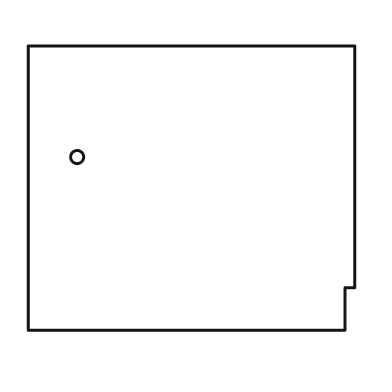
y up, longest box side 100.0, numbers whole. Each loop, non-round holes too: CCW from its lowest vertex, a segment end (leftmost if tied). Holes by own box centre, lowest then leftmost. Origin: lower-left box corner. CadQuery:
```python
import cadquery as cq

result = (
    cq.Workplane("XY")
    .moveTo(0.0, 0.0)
    .lineTo(97.0, 0.0)
    .lineTo(97.0, 13.0)
    .lineTo(100.0, 13.0)
    .lineTo(100.0, 87.0)
    .lineTo(0.0, 87.0)
    .close()
    .moveTo(15.0, 53.0)
    .circle(2.0)
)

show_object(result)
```